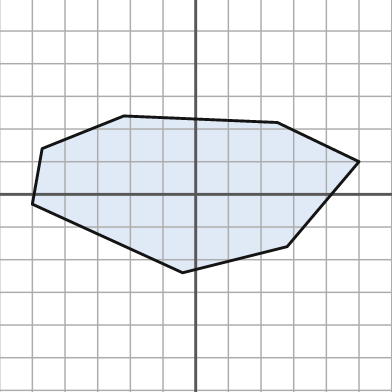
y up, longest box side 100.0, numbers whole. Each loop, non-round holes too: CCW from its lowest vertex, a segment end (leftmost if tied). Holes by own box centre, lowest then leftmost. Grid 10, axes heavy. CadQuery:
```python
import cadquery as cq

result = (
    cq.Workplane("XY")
    .moveTo(-4.0, -24.0)
    .lineTo(28.0, -16.0)
    .lineTo(50.0, 10.0)
    .lineTo(25.0, 22.0)
    .lineTo(-22.0, 24.0)
    .lineTo(-47.0, 14.0)
    .lineTo(-50.0, -3.0)
    .close()
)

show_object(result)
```